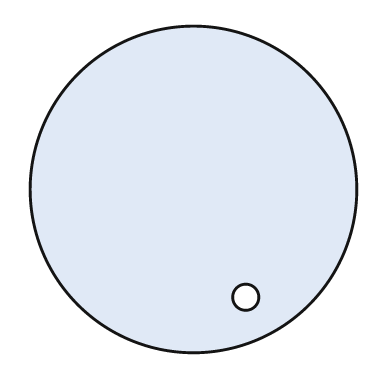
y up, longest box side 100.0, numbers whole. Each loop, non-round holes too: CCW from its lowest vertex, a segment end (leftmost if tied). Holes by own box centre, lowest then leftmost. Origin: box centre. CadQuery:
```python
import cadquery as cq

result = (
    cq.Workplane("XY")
    .moveTo(0.0, 0.0)
    .circle(50.0)
    .moveTo(16.0, -33.0)
    .circle(4.0)
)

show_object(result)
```